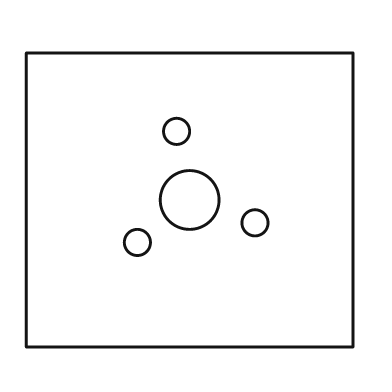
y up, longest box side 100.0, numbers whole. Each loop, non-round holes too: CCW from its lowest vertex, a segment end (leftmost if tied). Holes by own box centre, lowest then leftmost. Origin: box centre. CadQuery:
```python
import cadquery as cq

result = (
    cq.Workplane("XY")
    .moveTo(-50.0, -45.0)
    .lineTo(50.0, -45.0)
    .lineTo(50.0, 45.0)
    .lineTo(-50.0, 45.0)
    .close()
    .moveTo(-16.0, -13.0)
    .circle(4.0)
    .moveTo(20.0, -7.0)
    .circle(4.0)
    .moveTo(0.0, 0.0)
    .circle(9.0)
    .moveTo(-4.0, 21.0)
    .circle(4.0)
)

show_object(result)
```